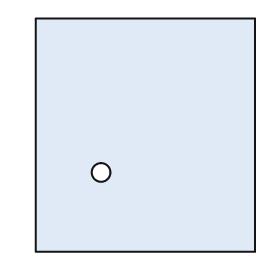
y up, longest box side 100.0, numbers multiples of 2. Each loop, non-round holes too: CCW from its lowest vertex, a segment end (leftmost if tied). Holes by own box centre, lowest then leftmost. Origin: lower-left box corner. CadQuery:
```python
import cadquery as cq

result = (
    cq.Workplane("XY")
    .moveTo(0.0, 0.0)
    .lineTo(94.0, 0.0)
    .lineTo(94.0, 100.0)
    .lineTo(0.0, 100.0)
    .close()
    .moveTo(28.0, 34.0)
    .circle(4.0)
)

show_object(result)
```